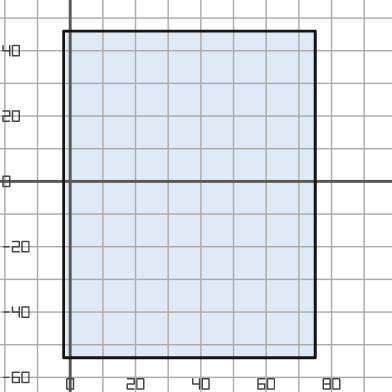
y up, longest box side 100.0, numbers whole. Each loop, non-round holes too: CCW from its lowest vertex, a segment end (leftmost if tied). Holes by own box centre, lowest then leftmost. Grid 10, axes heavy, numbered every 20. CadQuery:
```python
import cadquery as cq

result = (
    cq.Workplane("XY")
    .moveTo(-2.0, -54.0)
    .lineTo(75.0, -54.0)
    .lineTo(75.0, 46.0)
    .lineTo(-2.0, 46.0)
    .close()
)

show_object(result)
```